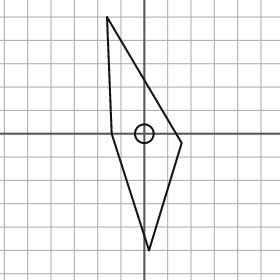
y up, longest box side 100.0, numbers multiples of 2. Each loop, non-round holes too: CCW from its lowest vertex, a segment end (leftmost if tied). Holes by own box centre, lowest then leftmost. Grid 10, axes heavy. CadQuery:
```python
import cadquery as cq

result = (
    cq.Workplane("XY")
    .moveTo(2.0, -50.0)
    .lineTo(16.0, -4.0)
    .lineTo(-16.0, 50.0)
    .lineTo(-14.0, 0.0)
    .close()
    .moveTo(0.0, 0.0)
    .circle(4.0)
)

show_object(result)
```